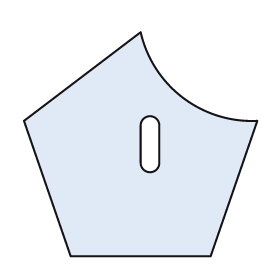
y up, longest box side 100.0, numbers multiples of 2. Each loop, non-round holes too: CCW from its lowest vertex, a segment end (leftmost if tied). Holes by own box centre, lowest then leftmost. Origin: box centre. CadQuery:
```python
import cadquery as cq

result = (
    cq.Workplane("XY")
    .moveTo(-30.0, -48.0)
    .lineTo(30.0, -48.0)
    .lineTo(50.0, 10.0)
    .threePointArc((18.0, 20.0), (0.0, 48.0))
    .lineTo(-50.0, 10.0)
    .close()
    .moveTo(0.0, -8.0)
    .threePointArc((4.0, -12.0), (8.0, -8.0))
    .lineTo(8.0, 8.0)
    .threePointArc((4.0, 12.0), (0.0, 8.0))
    .close()
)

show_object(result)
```